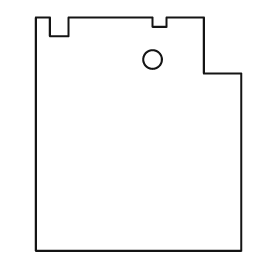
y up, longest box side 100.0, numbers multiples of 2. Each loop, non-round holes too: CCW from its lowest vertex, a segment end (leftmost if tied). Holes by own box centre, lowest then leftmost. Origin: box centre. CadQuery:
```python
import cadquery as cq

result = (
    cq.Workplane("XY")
    .moveTo(-44.0, -50.0)
    .lineTo(44.0, -50.0)
    .lineTo(44.0, 26.0)
    .lineTo(28.0, 26.0)
    .lineTo(28.0, 50.0)
    .lineTo(12.0, 50.0)
    .lineTo(12.0, 46.0)
    .lineTo(6.0, 46.0)
    .lineTo(6.0, 50.0)
    .lineTo(-30.0, 50.0)
    .lineTo(-30.0, 42.0)
    .lineTo(-38.0, 42.0)
    .lineTo(-38.0, 50.0)
    .lineTo(-44.0, 50.0)
    .close()
    .moveTo(6.0, 32.0)
    .circle(4.0)
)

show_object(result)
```